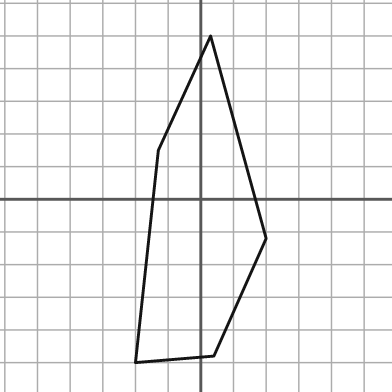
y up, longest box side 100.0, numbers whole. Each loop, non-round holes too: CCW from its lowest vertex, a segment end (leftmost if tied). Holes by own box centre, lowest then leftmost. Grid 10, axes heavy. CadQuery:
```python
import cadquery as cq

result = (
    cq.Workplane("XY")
    .moveTo(-20.0, -50.0)
    .lineTo(4.0, -48.0)
    .lineTo(20.0, -12.0)
    .lineTo(3.0, 50.0)
    .lineTo(-13.0, 15.0)
    .close()
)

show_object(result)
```